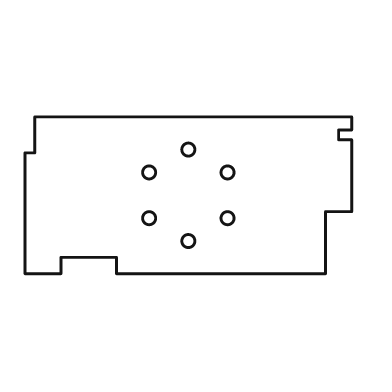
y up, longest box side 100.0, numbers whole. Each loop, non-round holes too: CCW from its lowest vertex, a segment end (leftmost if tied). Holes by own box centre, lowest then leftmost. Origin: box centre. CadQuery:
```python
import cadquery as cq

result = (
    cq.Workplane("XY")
    .moveTo(-50.0, -24.0)
    .lineTo(-39.0, -24.0)
    .lineTo(-39.0, -19.0)
    .lineTo(-22.0, -19.0)
    .lineTo(-22.0, -24.0)
    .lineTo(42.0, -24.0)
    .lineTo(42.0, -5.0)
    .lineTo(50.0, -5.0)
    .lineTo(50.0, 17.0)
    .lineTo(46.0, 17.0)
    .lineTo(46.0, 20.0)
    .lineTo(50.0, 20.0)
    .lineTo(50.0, 24.0)
    .lineTo(-47.0, 24.0)
    .lineTo(-47.0, 13.0)
    .lineTo(-50.0, 13.0)
    .close()
    .moveTo(0.0, -14.0)
    .circle(2.0)
    .moveTo(-12.0, -7.0)
    .circle(2.0)
    .moveTo(12.0, -7.0)
    .circle(2.0)
    .moveTo(-12.0, 7.0)
    .circle(2.0)
    .moveTo(12.0, 7.0)
    .circle(2.0)
    .moveTo(0.0, 14.0)
    .circle(2.0)
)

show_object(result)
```